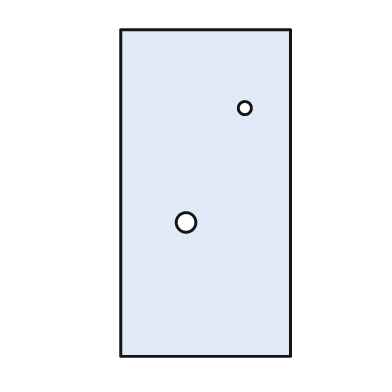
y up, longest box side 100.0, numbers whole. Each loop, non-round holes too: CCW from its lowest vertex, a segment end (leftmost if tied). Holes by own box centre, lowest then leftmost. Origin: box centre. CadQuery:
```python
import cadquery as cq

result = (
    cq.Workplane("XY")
    .moveTo(-26.0, -50.0)
    .lineTo(26.0, -50.0)
    .lineTo(26.0, 50.0)
    .lineTo(-26.0, 50.0)
    .close()
    .moveTo(-6.0, -9.0)
    .circle(3.0)
    .moveTo(12.0, 26.0)
    .circle(2.0)
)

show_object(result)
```